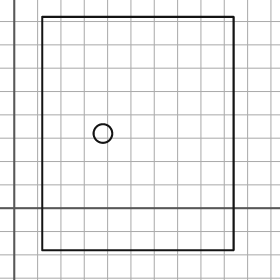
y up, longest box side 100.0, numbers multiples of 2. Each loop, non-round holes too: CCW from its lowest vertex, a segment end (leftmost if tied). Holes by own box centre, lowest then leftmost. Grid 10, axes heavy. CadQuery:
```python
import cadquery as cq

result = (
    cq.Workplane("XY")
    .moveTo(12.0, -18.0)
    .lineTo(94.0, -18.0)
    .lineTo(94.0, 82.0)
    .lineTo(12.0, 82.0)
    .close()
    .moveTo(38.0, 32.0)
    .circle(4.0)
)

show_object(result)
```